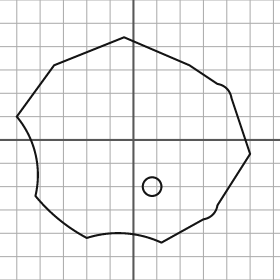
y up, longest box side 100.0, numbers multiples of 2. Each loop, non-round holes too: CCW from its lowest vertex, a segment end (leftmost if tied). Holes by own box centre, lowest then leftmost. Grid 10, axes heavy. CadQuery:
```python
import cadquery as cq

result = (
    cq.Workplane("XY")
    .moveTo(12.0, -44.0)
    .lineTo(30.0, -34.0)
    .threePointArc((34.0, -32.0), (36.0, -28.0))
    .lineTo(50.0, -6.0)
    .lineTo(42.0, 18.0)
    .threePointArc((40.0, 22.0), (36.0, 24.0))
    .lineTo(24.0, 32.0)
    .lineTo(-4.0, 44.0)
    .lineTo(-34.0, 32.0)
    .lineTo(-50.0, 10.0)
    .threePointArc((-42.0, -6.0), (-42.0, -24.0))
    .threePointArc((-32.0, -34.0), (-20.0, -42.0))
    .threePointArc((-4.0, -40.0), (12.0, -44.0))
    .close()
    .moveTo(8.0, -20.0)
    .circle(4.0)
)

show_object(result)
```